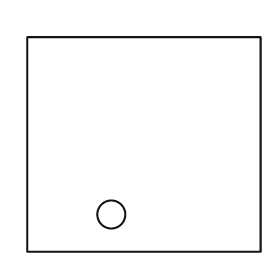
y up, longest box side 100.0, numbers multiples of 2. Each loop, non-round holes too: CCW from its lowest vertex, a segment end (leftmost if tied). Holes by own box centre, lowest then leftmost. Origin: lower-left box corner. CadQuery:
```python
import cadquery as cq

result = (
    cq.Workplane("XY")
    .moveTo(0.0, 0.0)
    .lineTo(100.0, 0.0)
    .lineTo(100.0, 92.0)
    .lineTo(0.0, 92.0)
    .close()
    .moveTo(36.0, 16.0)
    .circle(6.0)
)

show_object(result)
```